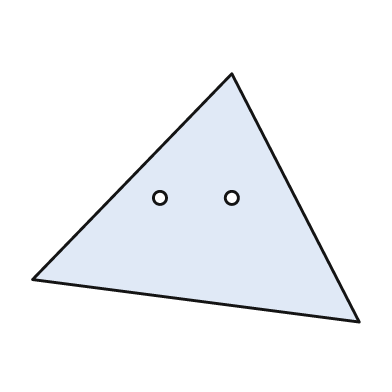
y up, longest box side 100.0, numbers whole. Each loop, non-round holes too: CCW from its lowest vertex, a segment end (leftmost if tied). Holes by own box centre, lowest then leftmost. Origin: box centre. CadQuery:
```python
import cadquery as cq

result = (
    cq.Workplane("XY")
    .moveTo(50.0, -38.0)
    .lineTo(11.0, 38.0)
    .lineTo(-50.0, -25.0)
    .close()
    .moveTo(-11.0, 0.0)
    .circle(2.0)
    .moveTo(11.0, 0.0)
    .circle(2.0)
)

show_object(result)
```